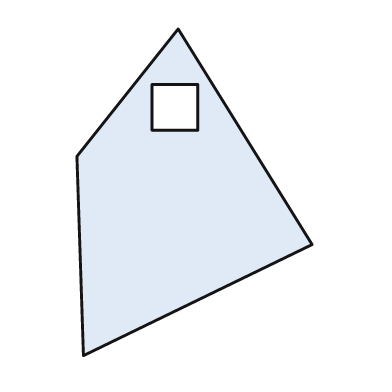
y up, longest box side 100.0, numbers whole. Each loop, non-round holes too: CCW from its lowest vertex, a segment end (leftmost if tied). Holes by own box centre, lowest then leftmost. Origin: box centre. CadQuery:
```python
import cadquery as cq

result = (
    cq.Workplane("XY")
    .moveTo(-34.0, -50.0)
    .lineTo(36.0, -16.0)
    .lineTo(-5.0, 50.0)
    .lineTo(-36.0, 11.0)
    .close()
    .moveTo(-13.0, 19.0)
    .lineTo(1.0, 19.0)
    .lineTo(1.0, 33.0)
    .lineTo(-13.0, 33.0)
    .close()
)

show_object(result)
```